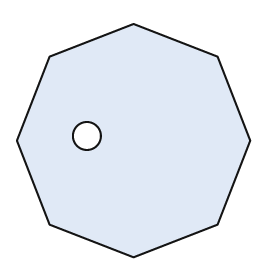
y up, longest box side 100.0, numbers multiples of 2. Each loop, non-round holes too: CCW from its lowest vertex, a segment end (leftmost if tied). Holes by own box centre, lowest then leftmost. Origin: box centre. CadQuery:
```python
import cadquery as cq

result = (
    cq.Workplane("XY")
    .moveTo(0.0, -50.0)
    .lineTo(36.0, -36.0)
    .lineTo(50.0, 0.0)
    .lineTo(36.0, 36.0)
    .lineTo(0.0, 50.0)
    .lineTo(-36.0, 36.0)
    .lineTo(-50.0, 0.0)
    .lineTo(-36.0, -36.0)
    .close()
    .moveTo(-20.0, 2.0)
    .circle(6.0)
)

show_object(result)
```